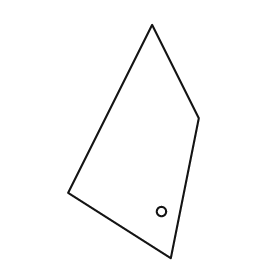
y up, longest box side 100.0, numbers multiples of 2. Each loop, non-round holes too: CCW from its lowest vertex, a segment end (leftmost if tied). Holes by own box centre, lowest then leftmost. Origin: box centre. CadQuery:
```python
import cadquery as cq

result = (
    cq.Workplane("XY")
    .moveTo(16.0, -50.0)
    .lineTo(28.0, 10.0)
    .lineTo(8.0, 50.0)
    .lineTo(-28.0, -22.0)
    .close()
    .moveTo(12.0, -30.0)
    .circle(2.0)
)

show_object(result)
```